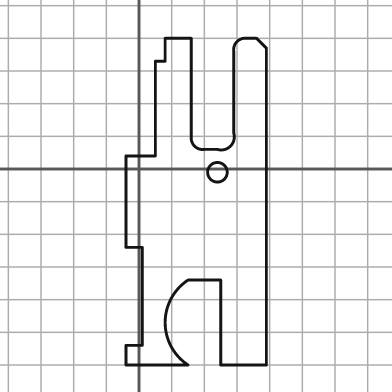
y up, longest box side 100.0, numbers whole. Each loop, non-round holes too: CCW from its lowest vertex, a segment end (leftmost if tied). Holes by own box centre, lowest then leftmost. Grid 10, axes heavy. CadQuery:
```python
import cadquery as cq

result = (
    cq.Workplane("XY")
    .moveTo(-4.0, -60.0)
    .lineTo(15.0, -60.0)
    .threePointArc((8.0, -47.0), (15.0, -34.0))
    .lineTo(25.0, -34.0)
    .lineTo(25.0, -60.0)
    .lineTo(39.0, -60.0)
    .lineTo(39.0, 37.0)
    .lineTo(36.0, 40.0)
    .lineTo(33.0, 40.0)
    .threePointArc((30.0, 39.0), (29.0, 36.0))
    .lineTo(29.0, 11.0)
    .threePointArc((28.0, 7.0), (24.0, 6.0))
    .lineTo(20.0, 6.0)
    .threePointArc((17.0, 7.0), (16.0, 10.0))
    .lineTo(16.0, 40.0)
    .lineTo(8.0, 40.0)
    .lineTo(8.0, 33.0)
    .lineTo(5.0, 33.0)
    .lineTo(5.0, 4.0)
    .lineTo(-4.0, 4.0)
    .lineTo(-4.0, -24.0)
    .lineTo(1.0, -24.0)
    .lineTo(1.0, -54.0)
    .lineTo(-4.0, -54.0)
    .close()
    .moveTo(24.0, -1.0)
    .circle(3.0)
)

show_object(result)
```